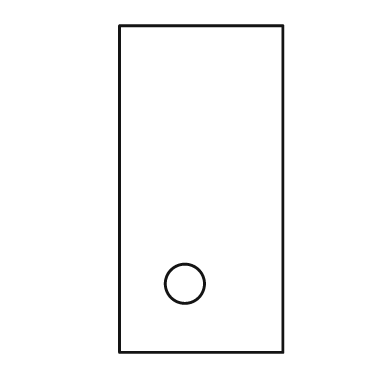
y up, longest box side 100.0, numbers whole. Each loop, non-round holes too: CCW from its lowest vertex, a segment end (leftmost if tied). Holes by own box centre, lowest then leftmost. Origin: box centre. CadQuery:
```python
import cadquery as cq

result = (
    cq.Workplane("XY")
    .moveTo(-25.0, -50.0)
    .lineTo(25.0, -50.0)
    .lineTo(25.0, 50.0)
    .lineTo(-25.0, 50.0)
    .close()
    .moveTo(-5.0, -29.0)
    .circle(6.0)
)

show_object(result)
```